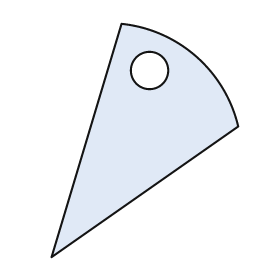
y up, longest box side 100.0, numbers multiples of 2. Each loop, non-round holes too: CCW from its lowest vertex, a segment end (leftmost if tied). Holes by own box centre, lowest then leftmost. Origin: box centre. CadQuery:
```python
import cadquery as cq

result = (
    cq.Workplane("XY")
    .moveTo(-40.0, -50.0)
    .lineTo(40.0, 6.0)
    .threePointArc((22.0, 36.0), (-10.0, 50.0))
    .close()
    .moveTo(2.0, 30.0)
    .circle(8.0)
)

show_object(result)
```